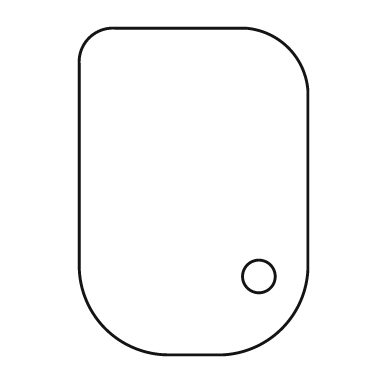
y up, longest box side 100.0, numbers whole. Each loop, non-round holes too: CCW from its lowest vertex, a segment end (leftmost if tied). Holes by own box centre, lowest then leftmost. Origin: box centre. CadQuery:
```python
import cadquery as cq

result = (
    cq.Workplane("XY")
    .moveTo(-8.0, -50.0)
    .lineTo(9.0, -50.0)
    .threePointArc((27.0, -42.0), (35.0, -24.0))
    .lineTo(35.0, 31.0)
    .threePointArc((29.0, 44.0), (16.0, 50.0))
    .lineTo(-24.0, 50.0)
    .threePointArc((-32.0, 47.0), (-35.0, 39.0))
    .lineTo(-35.0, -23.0)
    .threePointArc((-27.0, -42.0), (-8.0, -50.0))
    .close()
    .moveTo(20.0, -26.0)
    .circle(5.0)
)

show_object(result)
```